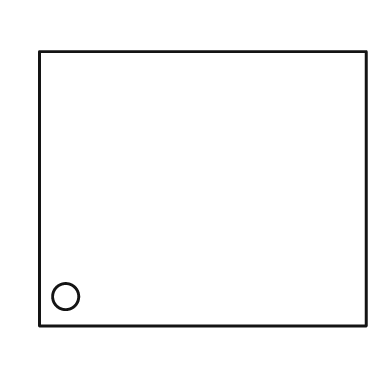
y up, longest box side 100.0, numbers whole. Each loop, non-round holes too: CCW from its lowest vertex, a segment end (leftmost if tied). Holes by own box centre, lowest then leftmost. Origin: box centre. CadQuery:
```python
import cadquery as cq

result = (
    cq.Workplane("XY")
    .moveTo(-50.0, -42.0)
    .lineTo(50.0, -42.0)
    .lineTo(50.0, 42.0)
    .lineTo(-50.0, 42.0)
    .close()
    .moveTo(-42.0, -33.0)
    .circle(4.0)
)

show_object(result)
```